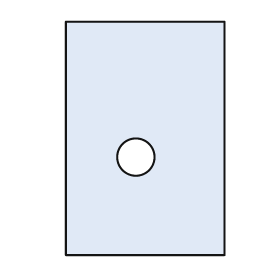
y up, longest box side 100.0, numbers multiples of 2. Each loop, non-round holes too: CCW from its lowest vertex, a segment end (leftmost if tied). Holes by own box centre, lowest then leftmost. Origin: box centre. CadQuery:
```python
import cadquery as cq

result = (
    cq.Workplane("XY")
    .moveTo(-34.0, -50.0)
    .lineTo(34.0, -50.0)
    .lineTo(34.0, 50.0)
    .lineTo(-34.0, 50.0)
    .close()
    .moveTo(-4.0, -8.0)
    .circle(8.0)
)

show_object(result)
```